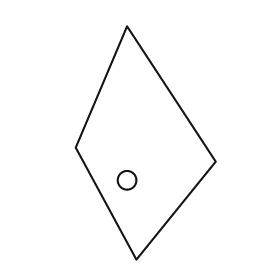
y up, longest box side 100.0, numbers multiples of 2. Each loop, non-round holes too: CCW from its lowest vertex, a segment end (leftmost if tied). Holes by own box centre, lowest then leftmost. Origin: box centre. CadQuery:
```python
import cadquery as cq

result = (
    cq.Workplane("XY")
    .moveTo(-4.0, -50.0)
    .lineTo(30.0, -8.0)
    .lineTo(-8.0, 50.0)
    .lineTo(-30.0, -2.0)
    .close()
    .moveTo(-8.0, -16.0)
    .circle(4.0)
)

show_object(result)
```